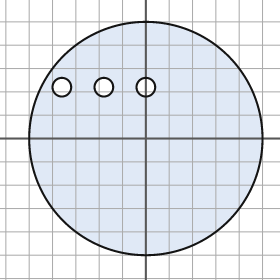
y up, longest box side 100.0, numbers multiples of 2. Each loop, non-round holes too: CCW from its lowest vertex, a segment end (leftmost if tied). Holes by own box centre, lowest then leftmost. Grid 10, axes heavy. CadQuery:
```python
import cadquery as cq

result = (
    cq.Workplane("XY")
    .moveTo(0.0, 0.0)
    .circle(50.0)
    .moveTo(-36.0, 22.0)
    .circle(4.0)
    .moveTo(-18.0, 22.0)
    .circle(4.0)
    .moveTo(0.0, 22.0)
    .circle(4.0)
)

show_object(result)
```